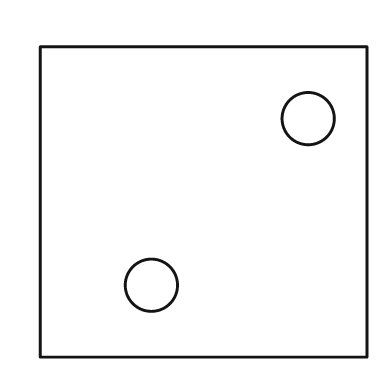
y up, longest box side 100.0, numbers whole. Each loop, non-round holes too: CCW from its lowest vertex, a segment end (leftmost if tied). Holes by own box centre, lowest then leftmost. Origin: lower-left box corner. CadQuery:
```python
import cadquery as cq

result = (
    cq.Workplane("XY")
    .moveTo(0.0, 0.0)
    .lineTo(100.0, 0.0)
    .lineTo(100.0, 95.0)
    .lineTo(0.0, 95.0)
    .close()
    .moveTo(34.0, 22.0)
    .circle(8.0)
    .moveTo(82.0, 73.0)
    .circle(8.0)
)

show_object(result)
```